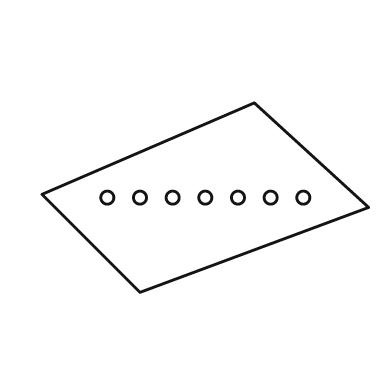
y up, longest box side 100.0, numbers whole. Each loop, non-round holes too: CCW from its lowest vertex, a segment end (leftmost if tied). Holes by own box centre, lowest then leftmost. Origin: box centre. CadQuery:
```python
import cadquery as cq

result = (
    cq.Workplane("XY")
    .moveTo(-20.0, -29.0)
    .lineTo(50.0, -3.0)
    .lineTo(15.0, 29.0)
    .lineTo(-50.0, 1.0)
    .close()
    .moveTo(-30.0, 0.0)
    .circle(2.0)
    .moveTo(-20.0, 0.0)
    .circle(2.0)
    .moveTo(-10.0, 0.0)
    .circle(2.0)
    .moveTo(0.0, 0.0)
    .circle(2.0)
    .moveTo(10.0, 0.0)
    .circle(2.0)
    .moveTo(20.0, 0.0)
    .circle(2.0)
    .moveTo(30.0, 0.0)
    .circle(2.0)
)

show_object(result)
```